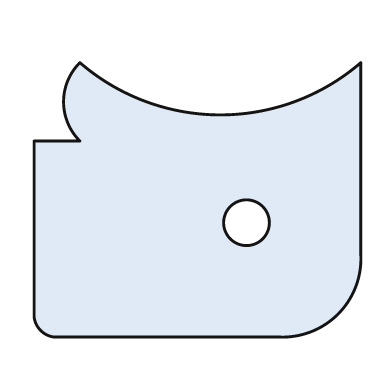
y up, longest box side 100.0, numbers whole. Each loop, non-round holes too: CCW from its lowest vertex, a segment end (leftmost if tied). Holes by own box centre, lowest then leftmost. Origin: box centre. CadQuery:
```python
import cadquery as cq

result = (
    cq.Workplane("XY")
    .moveTo(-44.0, -42.0)
    .lineTo(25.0, -42.0)
    .threePointArc((43.0, -35.0), (50.0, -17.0))
    .lineTo(50.0, 42.0)
    .threePointArc((7.0, 26.0), (-36.0, 42.0))
    .threePointArc((-41.0, 30.0), (-36.0, 18.0))
    .lineTo(-50.0, 18.0)
    .lineTo(-50.0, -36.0)
    .threePointArc((-48.0, -40.0), (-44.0, -42.0))
    .close()
    .moveTo(15.0, -7.0)
    .circle(7.0)
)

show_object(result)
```